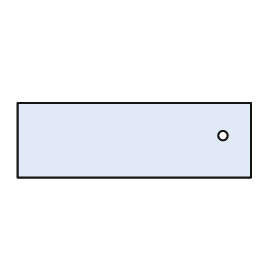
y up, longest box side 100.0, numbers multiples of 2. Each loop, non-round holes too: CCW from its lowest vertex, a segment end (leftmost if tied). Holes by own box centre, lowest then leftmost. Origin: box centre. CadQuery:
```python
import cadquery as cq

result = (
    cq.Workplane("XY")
    .moveTo(-50.0, -16.0)
    .lineTo(50.0, -16.0)
    .lineTo(50.0, 16.0)
    .lineTo(-50.0, 16.0)
    .close()
    .moveTo(38.0, 2.0)
    .circle(2.0)
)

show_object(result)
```